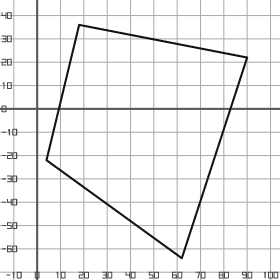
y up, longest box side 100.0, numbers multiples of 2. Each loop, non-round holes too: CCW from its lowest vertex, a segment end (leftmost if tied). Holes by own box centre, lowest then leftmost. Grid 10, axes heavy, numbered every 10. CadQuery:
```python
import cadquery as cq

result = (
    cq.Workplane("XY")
    .moveTo(62.0, -64.0)
    .lineTo(90.0, 22.0)
    .lineTo(18.0, 36.0)
    .lineTo(4.0, -22.0)
    .close()
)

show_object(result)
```